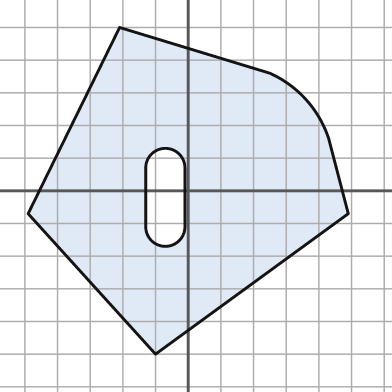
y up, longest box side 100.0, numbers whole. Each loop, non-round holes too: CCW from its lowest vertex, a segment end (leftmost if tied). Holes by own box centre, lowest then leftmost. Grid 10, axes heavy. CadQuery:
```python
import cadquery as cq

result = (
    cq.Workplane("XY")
    .moveTo(-10.0, -50.0)
    .lineTo(49.0, -7.0)
    .lineTo(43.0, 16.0)
    .threePointArc((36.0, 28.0), (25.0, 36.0))
    .lineTo(-21.0, 50.0)
    .lineTo(-49.0, -7.0)
    .close()
    .moveTo(-13.0, -11.0)
    .threePointArc((-7.0, -17.0), (-1.0, -11.0))
    .lineTo(-1.0, 7.0)
    .threePointArc((-7.0, 13.0), (-13.0, 7.0))
    .close()
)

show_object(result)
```